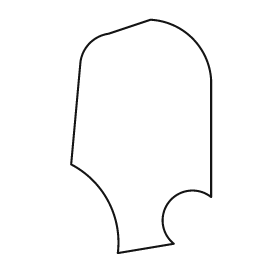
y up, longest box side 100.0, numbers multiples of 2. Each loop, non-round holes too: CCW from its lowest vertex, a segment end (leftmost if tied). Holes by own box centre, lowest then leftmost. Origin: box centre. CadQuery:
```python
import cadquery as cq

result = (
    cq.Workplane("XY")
    .moveTo(-10.0, -50.0)
    .lineTo(14.0, -46.0)
    .threePointArc((12.0, -28.0), (30.0, -26.0))
    .lineTo(30.0, 24.0)
    .threePointArc((22.0, 42.0), (4.0, 50.0))
    .lineTo(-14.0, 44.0)
    .threePointArc((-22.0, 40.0), (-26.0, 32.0))
    .lineTo(-30.0, -12.0)
    .threePointArc((-14.0, -28.0), (-10.0, -50.0))
    .close()
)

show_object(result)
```